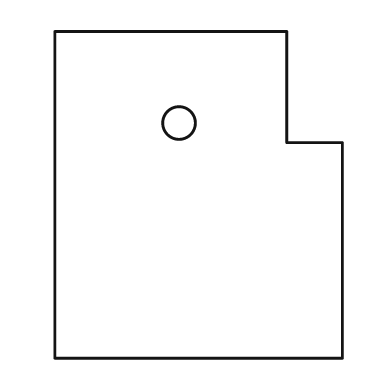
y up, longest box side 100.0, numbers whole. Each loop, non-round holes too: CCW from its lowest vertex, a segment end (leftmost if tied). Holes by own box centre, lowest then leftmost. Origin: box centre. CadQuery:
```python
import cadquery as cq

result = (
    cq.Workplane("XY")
    .moveTo(-44.0, -50.0)
    .lineTo(44.0, -50.0)
    .lineTo(44.0, 16.0)
    .lineTo(27.0, 16.0)
    .lineTo(27.0, 50.0)
    .lineTo(-44.0, 50.0)
    .close()
    .moveTo(-6.0, 22.0)
    .circle(5.0)
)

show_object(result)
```